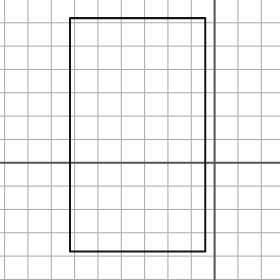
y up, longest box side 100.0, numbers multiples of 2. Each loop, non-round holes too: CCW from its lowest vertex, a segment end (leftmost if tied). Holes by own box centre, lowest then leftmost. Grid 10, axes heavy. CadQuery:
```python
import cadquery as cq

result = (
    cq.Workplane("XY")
    .moveTo(-62.0, -38.0)
    .lineTo(-4.0, -38.0)
    .lineTo(-4.0, 62.0)
    .lineTo(-62.0, 62.0)
    .close()
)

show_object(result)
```